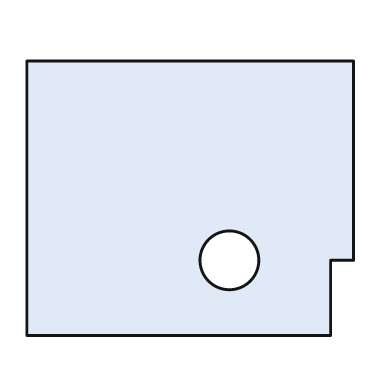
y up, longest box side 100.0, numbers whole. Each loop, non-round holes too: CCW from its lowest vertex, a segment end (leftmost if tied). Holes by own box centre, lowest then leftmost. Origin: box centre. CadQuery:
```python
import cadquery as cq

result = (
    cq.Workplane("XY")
    .moveTo(-50.0, -42.0)
    .lineTo(43.0, -42.0)
    .lineTo(43.0, -19.0)
    .lineTo(50.0, -19.0)
    .lineTo(50.0, 42.0)
    .lineTo(-50.0, 42.0)
    .close()
    .moveTo(12.0, -19.0)
    .circle(9.0)
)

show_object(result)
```